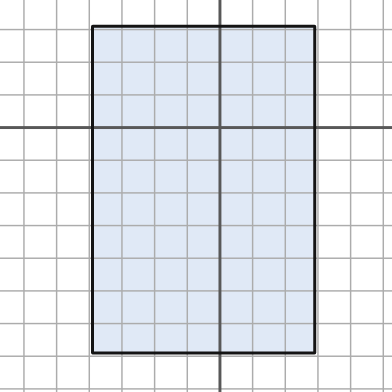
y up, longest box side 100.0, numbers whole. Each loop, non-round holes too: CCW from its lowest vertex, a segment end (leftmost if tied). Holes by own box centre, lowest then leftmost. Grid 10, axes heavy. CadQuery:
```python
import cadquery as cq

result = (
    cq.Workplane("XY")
    .moveTo(-39.0, -69.0)
    .lineTo(29.0, -69.0)
    .lineTo(29.0, 31.0)
    .lineTo(-39.0, 31.0)
    .close()
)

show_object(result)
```